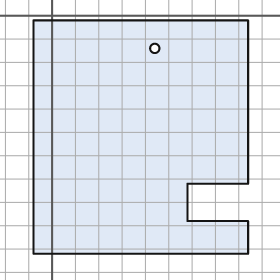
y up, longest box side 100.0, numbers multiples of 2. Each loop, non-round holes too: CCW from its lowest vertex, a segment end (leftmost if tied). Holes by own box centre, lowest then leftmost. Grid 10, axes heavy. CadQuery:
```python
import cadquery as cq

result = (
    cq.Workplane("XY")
    .moveTo(-8.0, -102.0)
    .lineTo(84.0, -102.0)
    .lineTo(84.0, -88.0)
    .lineTo(58.0, -88.0)
    .lineTo(58.0, -72.0)
    .lineTo(84.0, -72.0)
    .lineTo(84.0, -2.0)
    .lineTo(-8.0, -2.0)
    .close()
    .moveTo(44.0, -14.0)
    .circle(2.0)
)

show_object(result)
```